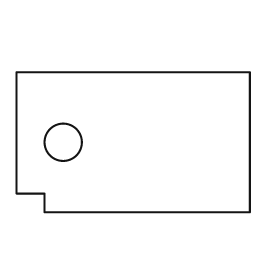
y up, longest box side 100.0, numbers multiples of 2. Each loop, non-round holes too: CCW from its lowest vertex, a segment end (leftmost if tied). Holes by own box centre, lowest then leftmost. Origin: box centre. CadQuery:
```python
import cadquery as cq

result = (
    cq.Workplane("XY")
    .moveTo(-38.0, -30.0)
    .lineTo(50.0, -30.0)
    .lineTo(50.0, 30.0)
    .lineTo(-50.0, 30.0)
    .lineTo(-50.0, -22.0)
    .lineTo(-38.0, -22.0)
    .close()
    .moveTo(-30.0, 0.0)
    .circle(8.0)
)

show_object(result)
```